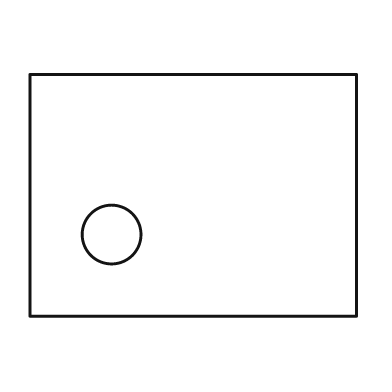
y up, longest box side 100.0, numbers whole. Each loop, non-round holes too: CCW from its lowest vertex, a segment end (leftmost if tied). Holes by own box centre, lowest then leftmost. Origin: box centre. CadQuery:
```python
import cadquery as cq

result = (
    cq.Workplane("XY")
    .moveTo(-50.0, -37.0)
    .lineTo(50.0, -37.0)
    .lineTo(50.0, 37.0)
    .lineTo(-50.0, 37.0)
    .close()
    .moveTo(-25.0, -12.0)
    .circle(9.0)
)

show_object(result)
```